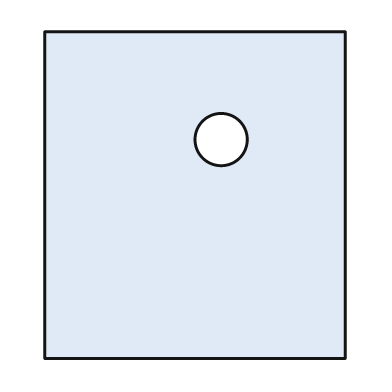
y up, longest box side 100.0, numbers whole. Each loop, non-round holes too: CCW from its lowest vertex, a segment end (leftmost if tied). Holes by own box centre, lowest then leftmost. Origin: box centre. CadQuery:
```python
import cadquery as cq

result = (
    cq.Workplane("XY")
    .moveTo(-46.0, -50.0)
    .lineTo(46.0, -50.0)
    .lineTo(46.0, 50.0)
    .lineTo(-46.0, 50.0)
    .close()
    .moveTo(8.0, 17.0)
    .circle(8.0)
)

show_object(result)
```